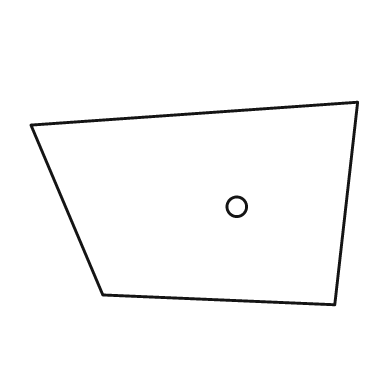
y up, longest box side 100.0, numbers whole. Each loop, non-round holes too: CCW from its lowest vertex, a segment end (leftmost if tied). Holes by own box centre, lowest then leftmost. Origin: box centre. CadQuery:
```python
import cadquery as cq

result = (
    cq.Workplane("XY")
    .moveTo(43.0, -31.0)
    .lineTo(50.0, 31.0)
    .lineTo(-50.0, 24.0)
    .lineTo(-28.0, -28.0)
    .close()
    .moveTo(13.0, -1.0)
    .circle(3.0)
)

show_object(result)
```